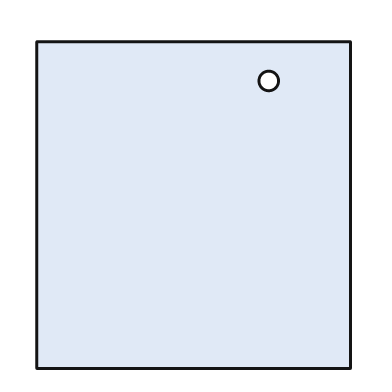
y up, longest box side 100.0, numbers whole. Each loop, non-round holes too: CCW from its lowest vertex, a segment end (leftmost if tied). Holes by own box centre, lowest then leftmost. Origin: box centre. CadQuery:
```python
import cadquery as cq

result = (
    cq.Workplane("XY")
    .moveTo(-48.0, -50.0)
    .lineTo(48.0, -50.0)
    .lineTo(48.0, 50.0)
    .lineTo(-48.0, 50.0)
    .close()
    .moveTo(23.0, 38.0)
    .circle(3.0)
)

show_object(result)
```